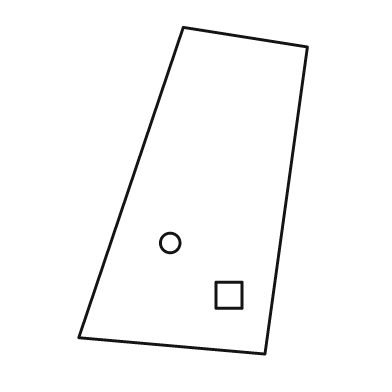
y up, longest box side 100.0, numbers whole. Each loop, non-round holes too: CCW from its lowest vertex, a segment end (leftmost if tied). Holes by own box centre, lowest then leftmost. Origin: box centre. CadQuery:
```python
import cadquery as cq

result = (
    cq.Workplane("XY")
    .moveTo(22.0, -50.0)
    .lineTo(35.0, 44.0)
    .lineTo(-3.0, 50.0)
    .lineTo(-35.0, -45.0)
    .close()
    .moveTo(7.0, -36.0)
    .lineTo(15.0, -36.0)
    .lineTo(15.0, -28.0)
    .lineTo(7.0, -28.0)
    .close()
    .moveTo(-7.0, -16.0)
    .circle(3.0)
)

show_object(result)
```